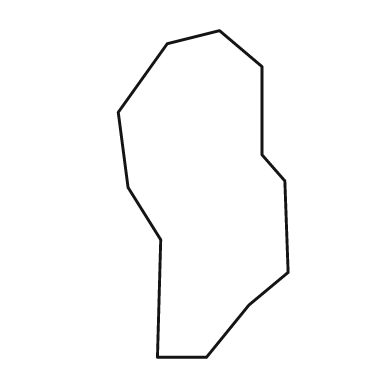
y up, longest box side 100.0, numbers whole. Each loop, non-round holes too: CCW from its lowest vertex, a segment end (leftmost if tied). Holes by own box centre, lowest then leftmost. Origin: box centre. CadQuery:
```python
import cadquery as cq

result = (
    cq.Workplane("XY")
    .moveTo(-14.0, -50.0)
    .lineTo(1.0, -50.0)
    .lineTo(14.0, -34.0)
    .lineTo(26.0, -24.0)
    .lineTo(25.0, 4.0)
    .lineTo(18.0, 12.0)
    .lineTo(18.0, 39.0)
    .lineTo(5.0, 50.0)
    .lineTo(-11.0, 46.0)
    .lineTo(-26.0, 25.0)
    .lineTo(-23.0, 2.0)
    .lineTo(-13.0, -14.0)
    .close()
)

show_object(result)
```